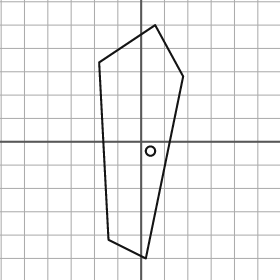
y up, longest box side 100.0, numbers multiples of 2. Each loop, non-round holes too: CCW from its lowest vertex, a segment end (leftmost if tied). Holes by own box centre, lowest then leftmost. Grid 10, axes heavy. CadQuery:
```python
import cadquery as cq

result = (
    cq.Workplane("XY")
    .moveTo(2.0, -50.0)
    .lineTo(18.0, 28.0)
    .lineTo(6.0, 50.0)
    .lineTo(-18.0, 34.0)
    .lineTo(-14.0, -42.0)
    .close()
    .moveTo(4.0, -4.0)
    .circle(2.0)
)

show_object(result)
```